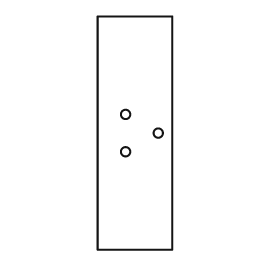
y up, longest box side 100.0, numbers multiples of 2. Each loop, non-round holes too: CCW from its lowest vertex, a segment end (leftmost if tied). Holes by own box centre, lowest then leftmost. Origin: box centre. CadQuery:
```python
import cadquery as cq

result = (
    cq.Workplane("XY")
    .moveTo(-16.0, -50.0)
    .lineTo(16.0, -50.0)
    .lineTo(16.0, 50.0)
    .lineTo(-16.0, 50.0)
    .close()
    .moveTo(-4.0, -8.0)
    .circle(2.0)
    .moveTo(10.0, 0.0)
    .circle(2.0)
    .moveTo(-4.0, 8.0)
    .circle(2.0)
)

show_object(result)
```